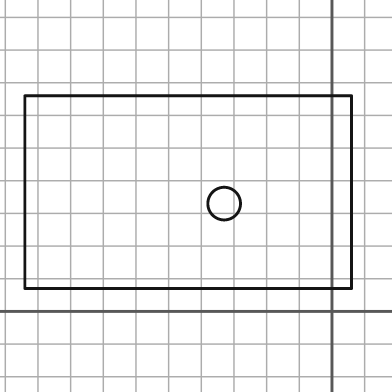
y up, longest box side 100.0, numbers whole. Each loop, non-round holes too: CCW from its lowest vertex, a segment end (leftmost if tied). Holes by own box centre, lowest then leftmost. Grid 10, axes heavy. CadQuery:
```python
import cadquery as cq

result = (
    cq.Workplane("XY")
    .moveTo(-94.0, 7.0)
    .lineTo(6.0, 7.0)
    .lineTo(6.0, 66.0)
    .lineTo(-94.0, 66.0)
    .close()
    .moveTo(-33.0, 33.0)
    .circle(5.0)
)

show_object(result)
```